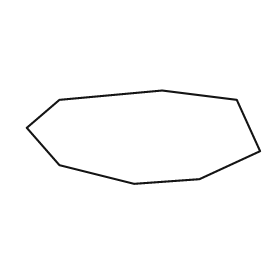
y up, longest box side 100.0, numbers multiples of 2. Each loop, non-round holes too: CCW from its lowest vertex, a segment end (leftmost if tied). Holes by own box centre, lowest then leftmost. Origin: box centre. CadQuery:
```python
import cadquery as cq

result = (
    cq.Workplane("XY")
    .moveTo(-4.0, -20.0)
    .lineTo(24.0, -18.0)
    .lineTo(50.0, -6.0)
    .lineTo(40.0, 16.0)
    .lineTo(8.0, 20.0)
    .lineTo(-36.0, 16.0)
    .lineTo(-50.0, 4.0)
    .lineTo(-36.0, -12.0)
    .close()
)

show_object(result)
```